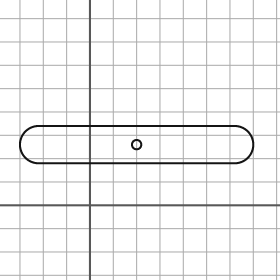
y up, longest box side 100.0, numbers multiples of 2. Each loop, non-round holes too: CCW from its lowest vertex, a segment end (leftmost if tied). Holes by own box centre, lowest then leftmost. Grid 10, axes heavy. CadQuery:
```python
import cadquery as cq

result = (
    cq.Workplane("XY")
    .moveTo(-22.0, 18.0)
    .lineTo(62.0, 18.0)
    .threePointArc((70.0, 26.0), (62.0, 34.0))
    .lineTo(-22.0, 34.0)
    .threePointArc((-30.0, 26.0), (-22.0, 18.0))
    .close()
    .moveTo(20.0, 26.0)
    .circle(2.0)
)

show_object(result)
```